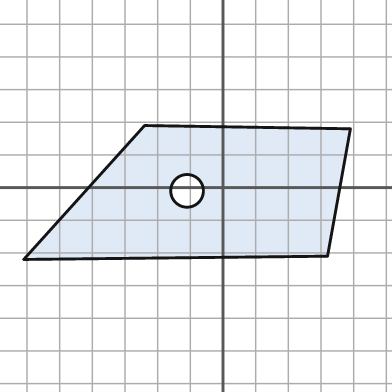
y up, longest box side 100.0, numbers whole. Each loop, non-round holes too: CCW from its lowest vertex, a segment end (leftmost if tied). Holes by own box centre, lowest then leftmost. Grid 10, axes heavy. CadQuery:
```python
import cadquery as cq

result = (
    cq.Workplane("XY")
    .moveTo(-61.0, -22.0)
    .lineTo(32.0, -21.0)
    .lineTo(39.0, 18.0)
    .lineTo(-24.0, 19.0)
    .close()
    .moveTo(-11.0, -1.0)
    .circle(5.0)
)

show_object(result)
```